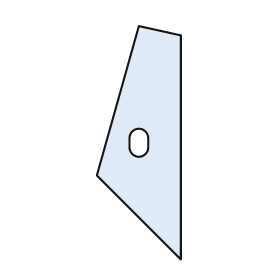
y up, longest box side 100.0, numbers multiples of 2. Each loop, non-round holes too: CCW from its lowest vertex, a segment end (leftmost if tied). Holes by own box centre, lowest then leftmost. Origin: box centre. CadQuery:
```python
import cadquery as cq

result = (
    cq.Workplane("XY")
    .moveTo(18.0, -50.0)
    .lineTo(18.0, 46.0)
    .lineTo(0.0, 50.0)
    .lineTo(-18.0, -14.0)
    .close()
    .moveTo(-4.0, -2.0)
    .threePointArc((0.0, -6.0), (4.0, -2.0))
    .lineTo(4.0, 2.0)
    .threePointArc((0.0, 6.0), (-4.0, 2.0))
    .close()
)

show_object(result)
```